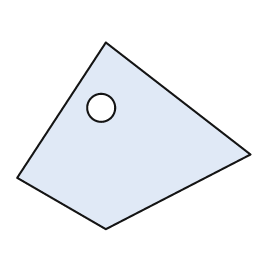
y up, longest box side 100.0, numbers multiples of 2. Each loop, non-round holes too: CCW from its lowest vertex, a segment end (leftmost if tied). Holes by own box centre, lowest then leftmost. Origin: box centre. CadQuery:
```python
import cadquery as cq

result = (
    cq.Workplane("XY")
    .moveTo(-12.0, -40.0)
    .lineTo(50.0, -8.0)
    .lineTo(-12.0, 40.0)
    .lineTo(-50.0, -18.0)
    .close()
    .moveTo(-14.0, 12.0)
    .circle(6.0)
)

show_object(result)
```